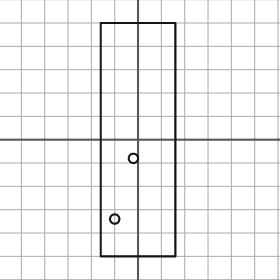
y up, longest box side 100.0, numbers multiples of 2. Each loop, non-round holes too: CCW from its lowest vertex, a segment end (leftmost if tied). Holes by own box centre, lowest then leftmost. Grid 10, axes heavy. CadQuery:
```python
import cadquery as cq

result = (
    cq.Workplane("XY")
    .moveTo(-16.0, -50.0)
    .lineTo(16.0, -50.0)
    .lineTo(16.0, 50.0)
    .lineTo(-16.0, 50.0)
    .close()
    .moveTo(-10.0, -34.0)
    .circle(2.0)
    .moveTo(-2.0, -8.0)
    .circle(2.0)
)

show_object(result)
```